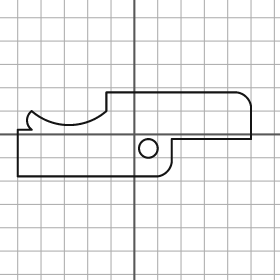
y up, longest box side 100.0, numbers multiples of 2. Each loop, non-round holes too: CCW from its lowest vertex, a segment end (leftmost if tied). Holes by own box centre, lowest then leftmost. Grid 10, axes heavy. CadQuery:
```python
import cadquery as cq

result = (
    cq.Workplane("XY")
    .moveTo(-50.0, -18.0)
    .lineTo(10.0, -18.0)
    .threePointArc((14.0, -16.0), (16.0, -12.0))
    .lineTo(16.0, -2.0)
    .lineTo(50.0, -2.0)
    .lineTo(50.0, 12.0)
    .threePointArc((48.0, 16.0), (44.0, 18.0))
    .lineTo(-12.0, 18.0)
    .lineTo(-12.0, 10.0)
    .threePointArc((-28.0, 4.0), (-44.0, 10.0))
    .threePointArc((-46.0, 6.0), (-44.0, 2.0))
    .lineTo(-50.0, 2.0)
    .close()
    .moveTo(6.0, -6.0)
    .circle(4.0)
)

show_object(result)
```